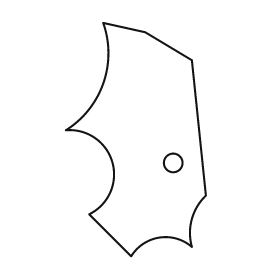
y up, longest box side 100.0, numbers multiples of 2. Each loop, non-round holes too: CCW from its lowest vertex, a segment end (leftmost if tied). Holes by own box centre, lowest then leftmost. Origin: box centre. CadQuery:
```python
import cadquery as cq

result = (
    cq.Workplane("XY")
    .moveTo(-2.0, -50.0)
    .threePointArc((10.0, -42.0), (24.0, -46.0))
    .threePointArc((24.0, -34.0), (30.0, -24.0))
    .lineTo(24.0, 34.0)
    .lineTo(4.0, 46.0)
    .lineTo(-14.0, 50.0)
    .threePointArc((-14.0, 24.0), (-30.0, 4.0))
    .threePointArc((-10.0, -10.0), (-20.0, -32.0))
    .close()
    .moveTo(16.0, -10.0)
    .circle(4.0)
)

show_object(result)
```